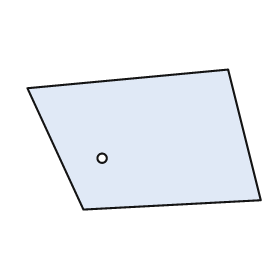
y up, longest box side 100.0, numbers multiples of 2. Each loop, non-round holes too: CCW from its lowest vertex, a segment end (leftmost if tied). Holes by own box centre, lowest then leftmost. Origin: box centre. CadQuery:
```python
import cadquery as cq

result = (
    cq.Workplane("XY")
    .moveTo(-26.0, -30.0)
    .lineTo(50.0, -26.0)
    .lineTo(36.0, 30.0)
    .lineTo(-50.0, 22.0)
    .close()
    .moveTo(-18.0, -8.0)
    .circle(2.0)
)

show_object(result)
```